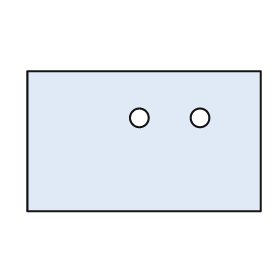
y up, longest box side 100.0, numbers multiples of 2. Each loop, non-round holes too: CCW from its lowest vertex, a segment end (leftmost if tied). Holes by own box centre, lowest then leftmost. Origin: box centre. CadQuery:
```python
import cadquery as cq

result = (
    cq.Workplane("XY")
    .moveTo(-50.0, -30.0)
    .lineTo(50.0, -30.0)
    .lineTo(50.0, 30.0)
    .lineTo(-50.0, 30.0)
    .close()
    .moveTo(-2.0, 10.0)
    .circle(4.0)
    .moveTo(24.0, 10.0)
    .circle(4.0)
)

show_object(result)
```